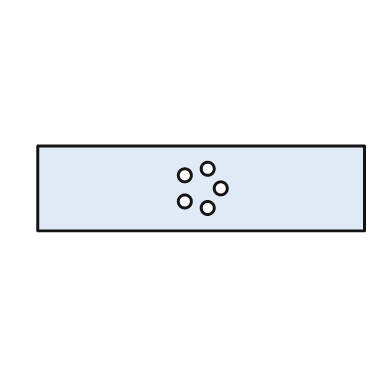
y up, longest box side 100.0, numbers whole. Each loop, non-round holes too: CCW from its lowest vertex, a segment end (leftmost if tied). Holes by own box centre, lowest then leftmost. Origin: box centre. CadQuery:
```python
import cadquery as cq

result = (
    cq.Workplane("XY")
    .moveTo(-50.0, -13.0)
    .lineTo(50.0, -13.0)
    .lineTo(50.0, 13.0)
    .lineTo(-50.0, 13.0)
    .close()
    .moveTo(2.0, -6.0)
    .circle(2.0)
    .moveTo(-5.0, -4.0)
    .circle(2.0)
    .moveTo(6.0, 0.0)
    .circle(2.0)
    .moveTo(-5.0, 4.0)
    .circle(2.0)
    .moveTo(2.0, 6.0)
    .circle(2.0)
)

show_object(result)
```